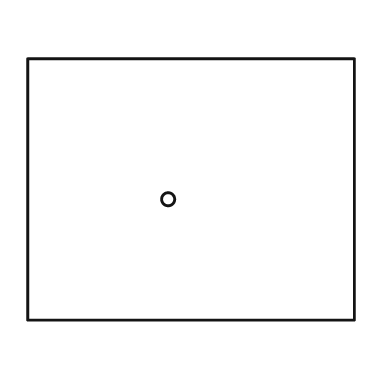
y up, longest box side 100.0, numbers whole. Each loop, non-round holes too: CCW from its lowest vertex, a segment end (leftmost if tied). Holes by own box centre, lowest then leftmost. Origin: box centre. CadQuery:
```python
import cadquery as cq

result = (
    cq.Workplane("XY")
    .moveTo(-50.0, -40.0)
    .lineTo(50.0, -40.0)
    .lineTo(50.0, 40.0)
    .lineTo(-50.0, 40.0)
    .close()
    .moveTo(-7.0, -3.0)
    .circle(2.0)
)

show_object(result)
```